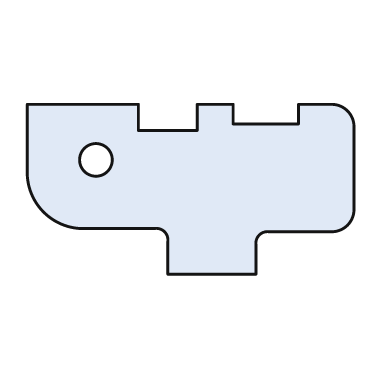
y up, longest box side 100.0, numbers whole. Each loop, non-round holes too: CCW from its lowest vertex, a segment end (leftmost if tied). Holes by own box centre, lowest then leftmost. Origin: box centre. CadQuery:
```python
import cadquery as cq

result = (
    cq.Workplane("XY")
    .moveTo(-7.0, -26.0)
    .lineTo(20.0, -26.0)
    .lineTo(20.0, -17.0)
    .threePointArc((21.0, -14.0), (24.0, -13.0))
    .lineTo(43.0, -13.0)
    .threePointArc((48.0, -11.0), (50.0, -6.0))
    .lineTo(50.0, 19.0)
    .threePointArc((48.0, 24.0), (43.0, 26.0))
    .lineTo(33.0, 26.0)
    .lineTo(33.0, 20.0)
    .lineTo(13.0, 20.0)
    .lineTo(13.0, 26.0)
    .lineTo(2.0, 26.0)
    .lineTo(2.0, 18.0)
    .lineTo(-16.0, 18.0)
    .lineTo(-16.0, 26.0)
    .lineTo(-50.0, 26.0)
    .lineTo(-50.0, 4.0)
    .threePointArc((-45.0, -7.0), (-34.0, -12.0))
    .lineTo(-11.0, -12.0)
    .threePointArc((-8.0, -13.0), (-7.0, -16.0))
    .close()
    .moveTo(-29.0, 9.0)
    .circle(5.0)
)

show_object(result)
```